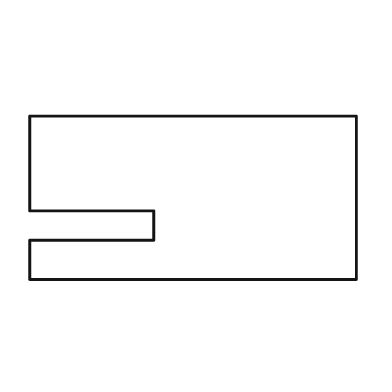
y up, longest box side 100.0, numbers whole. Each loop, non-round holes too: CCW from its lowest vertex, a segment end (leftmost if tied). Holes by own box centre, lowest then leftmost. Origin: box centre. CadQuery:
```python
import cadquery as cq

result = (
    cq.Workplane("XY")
    .moveTo(-50.0, -25.0)
    .lineTo(50.0, -25.0)
    .lineTo(50.0, 25.0)
    .lineTo(-50.0, 25.0)
    .lineTo(-50.0, -4.0)
    .lineTo(-12.0, -4.0)
    .lineTo(-12.0, -13.0)
    .lineTo(-50.0, -13.0)
    .close()
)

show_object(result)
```